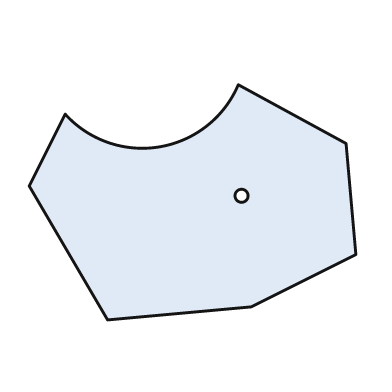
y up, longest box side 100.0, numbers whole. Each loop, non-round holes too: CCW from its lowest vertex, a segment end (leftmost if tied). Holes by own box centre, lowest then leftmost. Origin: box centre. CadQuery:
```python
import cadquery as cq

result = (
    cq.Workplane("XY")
    .moveTo(-26.0, -36.0)
    .lineTo(18.0, -32.0)
    .lineTo(50.0, -16.0)
    .lineTo(47.0, 18.0)
    .lineTo(14.0, 36.0)
    .threePointArc((-10.0, 17.0), (-39.0, 27.0))
    .lineTo(-50.0, 5.0)
    .close()
    .moveTo(15.0, 2.0)
    .circle(2.0)
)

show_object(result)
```